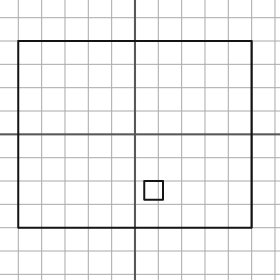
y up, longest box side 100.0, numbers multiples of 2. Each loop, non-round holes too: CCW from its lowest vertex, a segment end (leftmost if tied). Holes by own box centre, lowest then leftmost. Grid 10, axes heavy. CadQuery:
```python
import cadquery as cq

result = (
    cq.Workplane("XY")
    .moveTo(-50.0, -40.0)
    .lineTo(50.0, -40.0)
    .lineTo(50.0, 40.0)
    .lineTo(-50.0, 40.0)
    .close()
    .moveTo(4.0, -28.0)
    .lineTo(12.0, -28.0)
    .lineTo(12.0, -20.0)
    .lineTo(4.0, -20.0)
    .close()
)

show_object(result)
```